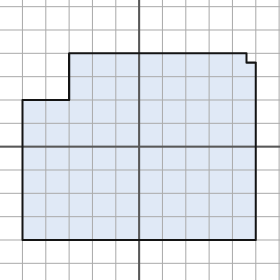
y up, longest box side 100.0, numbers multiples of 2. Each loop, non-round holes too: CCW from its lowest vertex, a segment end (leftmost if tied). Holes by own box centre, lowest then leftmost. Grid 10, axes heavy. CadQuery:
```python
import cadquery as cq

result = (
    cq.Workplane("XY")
    .moveTo(-50.0, -40.0)
    .lineTo(50.0, -40.0)
    .lineTo(50.0, 36.0)
    .lineTo(46.0, 36.0)
    .lineTo(46.0, 40.0)
    .lineTo(-30.0, 40.0)
    .lineTo(-30.0, 20.0)
    .lineTo(-50.0, 20.0)
    .close()
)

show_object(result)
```